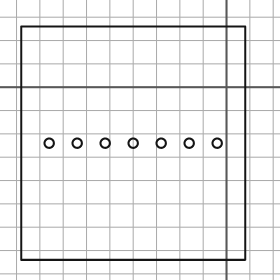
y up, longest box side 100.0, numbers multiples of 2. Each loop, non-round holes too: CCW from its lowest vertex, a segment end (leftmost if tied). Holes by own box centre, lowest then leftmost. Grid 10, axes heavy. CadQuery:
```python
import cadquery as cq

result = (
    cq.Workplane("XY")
    .moveTo(-88.0, -74.0)
    .lineTo(8.0, -74.0)
    .lineTo(8.0, 26.0)
    .lineTo(-88.0, 26.0)
    .close()
    .moveTo(-76.0, -24.0)
    .circle(2.0)
    .moveTo(-64.0, -24.0)
    .circle(2.0)
    .moveTo(-52.0, -24.0)
    .circle(2.0)
    .moveTo(-40.0, -24.0)
    .circle(2.0)
    .moveTo(-28.0, -24.0)
    .circle(2.0)
    .moveTo(-16.0, -24.0)
    .circle(2.0)
    .moveTo(-4.0, -24.0)
    .circle(2.0)
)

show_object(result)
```